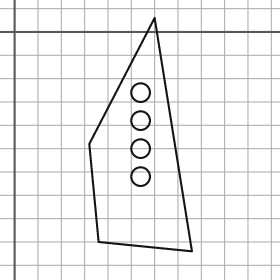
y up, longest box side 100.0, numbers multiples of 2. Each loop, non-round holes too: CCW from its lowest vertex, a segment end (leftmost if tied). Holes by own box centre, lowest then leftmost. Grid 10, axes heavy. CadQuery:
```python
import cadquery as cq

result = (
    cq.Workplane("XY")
    .moveTo(76.0, -94.0)
    .lineTo(60.0, 6.0)
    .lineTo(32.0, -48.0)
    .lineTo(36.0, -90.0)
    .close()
    .moveTo(54.0, -62.0)
    .circle(4.0)
    .moveTo(54.0, -50.0)
    .circle(4.0)
    .moveTo(54.0, -38.0)
    .circle(4.0)
    .moveTo(54.0, -26.0)
    .circle(4.0)
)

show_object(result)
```